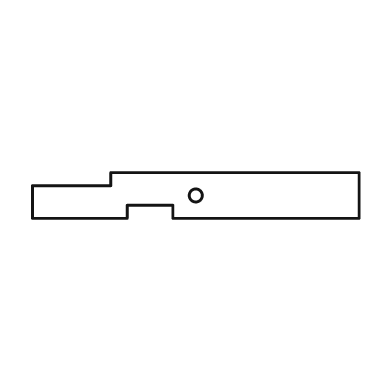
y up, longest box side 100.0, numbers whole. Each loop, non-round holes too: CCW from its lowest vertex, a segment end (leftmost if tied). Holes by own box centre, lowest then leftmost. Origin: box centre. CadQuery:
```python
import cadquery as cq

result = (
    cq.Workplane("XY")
    .moveTo(-50.0, -7.0)
    .lineTo(-21.0, -7.0)
    .lineTo(-21.0, -3.0)
    .lineTo(-7.0, -3.0)
    .lineTo(-7.0, -7.0)
    .lineTo(50.0, -7.0)
    .lineTo(50.0, 7.0)
    .lineTo(-26.0, 7.0)
    .lineTo(-26.0, 3.0)
    .lineTo(-50.0, 3.0)
    .close()
    .moveTo(0.0, 0.0)
    .circle(2.0)
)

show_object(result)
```